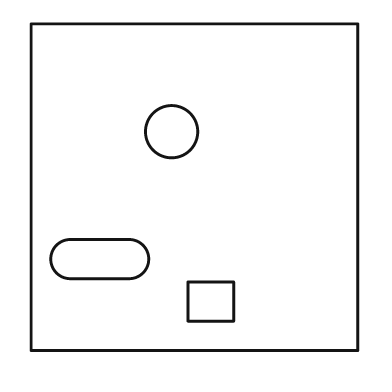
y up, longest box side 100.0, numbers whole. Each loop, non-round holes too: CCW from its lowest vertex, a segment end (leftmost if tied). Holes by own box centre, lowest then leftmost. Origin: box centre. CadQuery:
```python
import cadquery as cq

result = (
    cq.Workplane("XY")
    .moveTo(-50.0, -50.0)
    .lineTo(50.0, -50.0)
    .lineTo(50.0, 50.0)
    .lineTo(-50.0, 50.0)
    .close()
    .moveTo(-2.0, -41.0)
    .lineTo(12.0, -41.0)
    .lineTo(12.0, -29.0)
    .lineTo(-2.0, -29.0)
    .close()
    .moveTo(-38.0, -28.0)
    .lineTo(-20.0, -28.0)
    .threePointArc((-14.0, -22.0), (-20.0, -16.0))
    .lineTo(-38.0, -16.0)
    .threePointArc((-44.0, -22.0), (-38.0, -28.0))
    .close()
    .moveTo(-7.0, 17.0)
    .circle(8.0)
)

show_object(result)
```